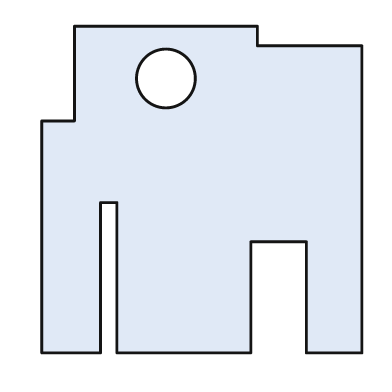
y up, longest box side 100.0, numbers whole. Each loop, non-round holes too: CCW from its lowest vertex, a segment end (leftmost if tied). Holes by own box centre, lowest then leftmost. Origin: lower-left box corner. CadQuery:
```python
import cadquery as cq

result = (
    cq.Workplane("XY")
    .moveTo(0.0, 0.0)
    .lineTo(18.0, 0.0)
    .lineTo(18.0, 46.0)
    .lineTo(23.0, 46.0)
    .lineTo(23.0, 0.0)
    .lineTo(64.0, 0.0)
    .lineTo(64.0, 34.0)
    .lineTo(81.0, 34.0)
    .lineTo(81.0, 0.0)
    .lineTo(98.0, 0.0)
    .lineTo(98.0, 94.0)
    .lineTo(66.0, 94.0)
    .lineTo(66.0, 100.0)
    .lineTo(10.0, 100.0)
    .lineTo(10.0, 71.0)
    .lineTo(0.0, 71.0)
    .close()
    .moveTo(38.0, 84.0)
    .circle(9.0)
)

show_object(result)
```